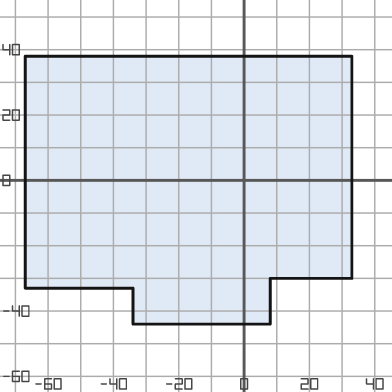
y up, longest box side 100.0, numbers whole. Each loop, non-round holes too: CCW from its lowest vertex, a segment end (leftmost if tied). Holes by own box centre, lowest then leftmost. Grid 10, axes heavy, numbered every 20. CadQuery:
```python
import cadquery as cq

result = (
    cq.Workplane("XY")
    .moveTo(-34.0, -44.0)
    .lineTo(8.0, -44.0)
    .lineTo(8.0, -30.0)
    .lineTo(33.0, -30.0)
    .lineTo(33.0, 38.0)
    .lineTo(-67.0, 38.0)
    .lineTo(-67.0, -33.0)
    .lineTo(-34.0, -33.0)
    .close()
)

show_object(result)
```